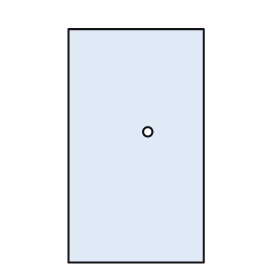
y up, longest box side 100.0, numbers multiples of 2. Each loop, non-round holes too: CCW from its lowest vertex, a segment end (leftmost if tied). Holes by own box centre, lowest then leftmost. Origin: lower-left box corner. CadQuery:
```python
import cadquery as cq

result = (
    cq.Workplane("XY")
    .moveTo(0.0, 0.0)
    .lineTo(58.0, 0.0)
    .lineTo(58.0, 100.0)
    .lineTo(0.0, 100.0)
    .close()
    .moveTo(34.0, 56.0)
    .circle(2.0)
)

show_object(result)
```